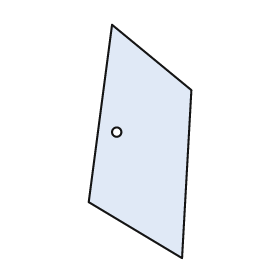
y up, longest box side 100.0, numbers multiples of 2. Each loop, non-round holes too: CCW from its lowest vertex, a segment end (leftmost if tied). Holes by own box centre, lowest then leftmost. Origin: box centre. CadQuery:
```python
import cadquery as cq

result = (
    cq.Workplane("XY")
    .moveTo(18.0, -50.0)
    .lineTo(22.0, 22.0)
    .lineTo(-12.0, 50.0)
    .lineTo(-22.0, -26.0)
    .close()
    .moveTo(-10.0, 4.0)
    .circle(2.0)
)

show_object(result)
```